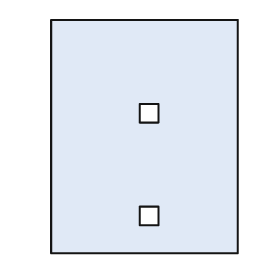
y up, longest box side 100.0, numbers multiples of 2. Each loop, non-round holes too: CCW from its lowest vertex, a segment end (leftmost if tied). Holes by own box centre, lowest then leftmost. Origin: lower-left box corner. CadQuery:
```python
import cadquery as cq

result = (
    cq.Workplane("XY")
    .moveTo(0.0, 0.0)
    .lineTo(80.0, 0.0)
    .lineTo(80.0, 100.0)
    .lineTo(0.0, 100.0)
    .close()
    .moveTo(38.0, 12.0)
    .lineTo(46.0, 12.0)
    .lineTo(46.0, 20.0)
    .lineTo(38.0, 20.0)
    .close()
    .moveTo(38.0, 56.0)
    .lineTo(46.0, 56.0)
    .lineTo(46.0, 64.0)
    .lineTo(38.0, 64.0)
    .close()
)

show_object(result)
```